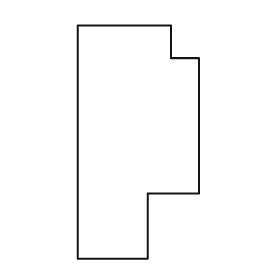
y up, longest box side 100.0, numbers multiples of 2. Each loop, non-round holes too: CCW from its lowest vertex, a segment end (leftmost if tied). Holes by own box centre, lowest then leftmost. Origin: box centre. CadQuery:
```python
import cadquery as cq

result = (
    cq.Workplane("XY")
    .moveTo(-26.0, -50.0)
    .lineTo(4.0, -50.0)
    .lineTo(4.0, -22.0)
    .lineTo(26.0, -22.0)
    .lineTo(26.0, 36.0)
    .lineTo(14.0, 36.0)
    .lineTo(14.0, 50.0)
    .lineTo(-26.0, 50.0)
    .close()
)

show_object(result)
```